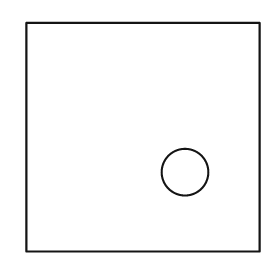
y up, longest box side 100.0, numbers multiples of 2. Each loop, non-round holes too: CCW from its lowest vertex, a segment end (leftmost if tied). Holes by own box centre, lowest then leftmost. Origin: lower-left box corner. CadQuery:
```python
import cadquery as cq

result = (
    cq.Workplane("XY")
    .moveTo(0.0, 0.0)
    .lineTo(100.0, 0.0)
    .lineTo(100.0, 98.0)
    .lineTo(0.0, 98.0)
    .close()
    .moveTo(68.0, 34.0)
    .circle(10.0)
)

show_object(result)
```